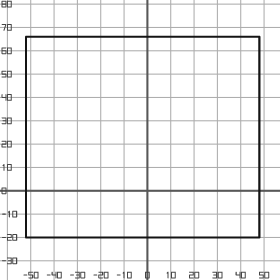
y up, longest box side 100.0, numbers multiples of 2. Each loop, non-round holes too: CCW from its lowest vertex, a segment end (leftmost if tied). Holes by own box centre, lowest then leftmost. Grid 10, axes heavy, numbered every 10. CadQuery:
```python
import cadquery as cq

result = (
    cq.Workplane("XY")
    .moveTo(-52.0, -20.0)
    .lineTo(48.0, -20.0)
    .lineTo(48.0, 66.0)
    .lineTo(-52.0, 66.0)
    .close()
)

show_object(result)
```